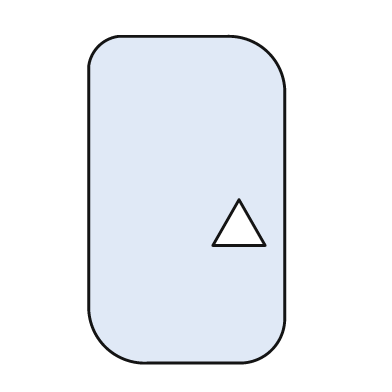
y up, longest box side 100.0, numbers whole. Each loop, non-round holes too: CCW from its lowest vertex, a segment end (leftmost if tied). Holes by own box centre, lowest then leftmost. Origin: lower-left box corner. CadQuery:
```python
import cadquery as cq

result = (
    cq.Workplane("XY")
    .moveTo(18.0, 0.0)
    .lineTo(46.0, 0.0)
    .threePointArc((56.0, 4.0), (60.0, 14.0))
    .lineTo(60.0, 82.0)
    .threePointArc((55.0, 95.0), (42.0, 100.0))
    .lineTo(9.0, 100.0)
    .threePointArc((3.0, 97.0), (0.0, 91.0))
    .lineTo(0.0, 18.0)
    .threePointArc((5.0, 5.0), (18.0, 0.0))
    .close()
    .moveTo(38.0, 36.0)
    .lineTo(54.0, 36.0)
    .lineTo(46.0, 50.0)
    .close()
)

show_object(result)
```